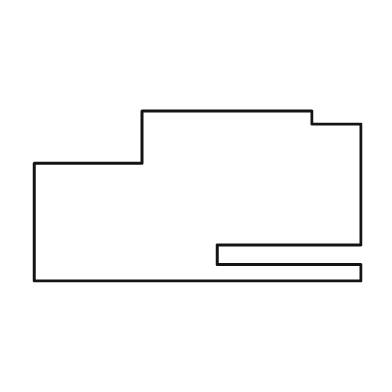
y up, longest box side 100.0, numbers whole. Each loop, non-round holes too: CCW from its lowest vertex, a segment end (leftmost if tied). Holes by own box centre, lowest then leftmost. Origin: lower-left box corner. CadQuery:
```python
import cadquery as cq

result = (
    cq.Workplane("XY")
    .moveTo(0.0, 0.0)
    .lineTo(100.0, 0.0)
    .lineTo(100.0, 5.0)
    .lineTo(56.0, 5.0)
    .lineTo(56.0, 11.0)
    .lineTo(100.0, 11.0)
    .lineTo(100.0, 48.0)
    .lineTo(85.0, 48.0)
    .lineTo(85.0, 52.0)
    .lineTo(33.0, 52.0)
    .lineTo(33.0, 36.0)
    .lineTo(0.0, 36.0)
    .close()
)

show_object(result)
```